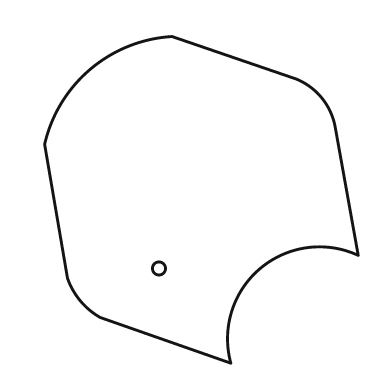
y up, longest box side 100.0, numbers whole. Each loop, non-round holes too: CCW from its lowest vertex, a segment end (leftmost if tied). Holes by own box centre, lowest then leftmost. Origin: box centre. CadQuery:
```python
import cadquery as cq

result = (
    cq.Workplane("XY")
    .moveTo(9.0, -50.0)
    .threePointArc((18.0, -21.0), (48.0, -17.0))
    .lineTo(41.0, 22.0)
    .threePointArc((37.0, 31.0), (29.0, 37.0))
    .lineTo(-9.0, 50.0)
    .threePointArc((-34.0, 40.0), (-48.0, 17.0))
    .lineTo(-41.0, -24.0)
    .threePointArc((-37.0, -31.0), (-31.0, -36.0))
    .close()
    .moveTo(-13.0, -21.0)
    .circle(2.0)
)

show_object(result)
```